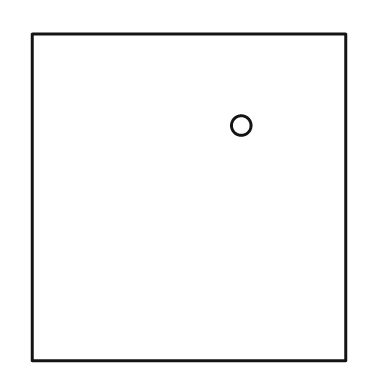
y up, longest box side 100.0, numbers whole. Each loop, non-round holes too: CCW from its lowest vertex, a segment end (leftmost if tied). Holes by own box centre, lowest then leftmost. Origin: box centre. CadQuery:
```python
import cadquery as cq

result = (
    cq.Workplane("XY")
    .moveTo(-48.0, -50.0)
    .lineTo(48.0, -50.0)
    .lineTo(48.0, 50.0)
    .lineTo(-48.0, 50.0)
    .close()
    .moveTo(16.0, 22.0)
    .circle(3.0)
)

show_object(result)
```